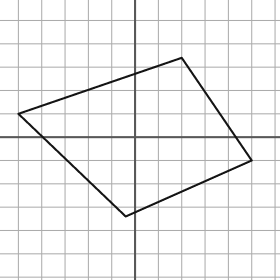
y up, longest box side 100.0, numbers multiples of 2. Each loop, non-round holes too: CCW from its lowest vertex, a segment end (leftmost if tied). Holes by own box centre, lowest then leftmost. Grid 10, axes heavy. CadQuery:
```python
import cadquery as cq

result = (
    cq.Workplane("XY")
    .moveTo(-4.0, -34.0)
    .lineTo(50.0, -10.0)
    .lineTo(20.0, 34.0)
    .lineTo(-50.0, 10.0)
    .close()
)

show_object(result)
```